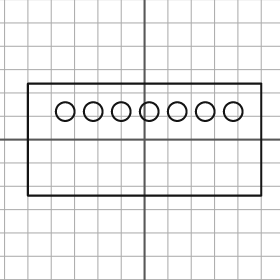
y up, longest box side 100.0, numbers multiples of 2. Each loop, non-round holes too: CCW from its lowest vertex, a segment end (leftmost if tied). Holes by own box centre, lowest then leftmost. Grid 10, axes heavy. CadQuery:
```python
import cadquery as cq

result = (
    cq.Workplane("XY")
    .moveTo(-50.0, -24.0)
    .lineTo(50.0, -24.0)
    .lineTo(50.0, 24.0)
    .lineTo(-50.0, 24.0)
    .close()
    .moveTo(-34.0, 12.0)
    .circle(4.0)
    .moveTo(-22.0, 12.0)
    .circle(4.0)
    .moveTo(-10.0, 12.0)
    .circle(4.0)
    .moveTo(2.0, 12.0)
    .circle(4.0)
    .moveTo(14.0, 12.0)
    .circle(4.0)
    .moveTo(26.0, 12.0)
    .circle(4.0)
    .moveTo(38.0, 12.0)
    .circle(4.0)
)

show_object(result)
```